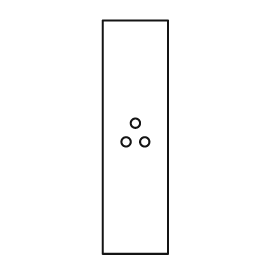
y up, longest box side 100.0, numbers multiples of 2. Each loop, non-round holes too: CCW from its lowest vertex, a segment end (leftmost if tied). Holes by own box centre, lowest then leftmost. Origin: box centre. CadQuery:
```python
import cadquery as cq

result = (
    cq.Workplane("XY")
    .moveTo(-14.0, -50.0)
    .lineTo(14.0, -50.0)
    .lineTo(14.0, 50.0)
    .lineTo(-14.0, 50.0)
    .close()
    .moveTo(-4.0, -2.0)
    .circle(2.0)
    .moveTo(4.0, -2.0)
    .circle(2.0)
    .moveTo(0.0, 6.0)
    .circle(2.0)
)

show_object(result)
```